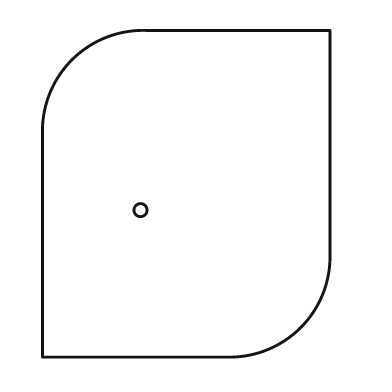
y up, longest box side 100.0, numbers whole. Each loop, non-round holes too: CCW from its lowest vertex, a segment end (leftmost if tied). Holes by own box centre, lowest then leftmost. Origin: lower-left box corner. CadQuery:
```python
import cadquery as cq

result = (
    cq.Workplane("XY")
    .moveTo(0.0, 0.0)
    .lineTo(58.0, 0.0)
    .threePointArc((79.0, 9.0), (88.0, 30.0))
    .lineTo(88.0, 100.0)
    .lineTo(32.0, 100.0)
    .threePointArc((9.0, 91.0), (0.0, 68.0))
    .close()
    .moveTo(30.0, 45.0)
    .circle(2.0)
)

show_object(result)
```